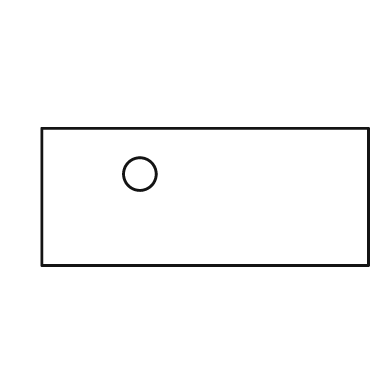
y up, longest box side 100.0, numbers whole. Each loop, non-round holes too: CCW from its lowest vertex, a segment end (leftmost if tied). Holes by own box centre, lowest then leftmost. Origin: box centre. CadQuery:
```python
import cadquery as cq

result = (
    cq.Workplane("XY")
    .moveTo(-50.0, -21.0)
    .lineTo(50.0, -21.0)
    .lineTo(50.0, 21.0)
    .lineTo(-50.0, 21.0)
    .close()
    .moveTo(-20.0, 7.0)
    .circle(5.0)
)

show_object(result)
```